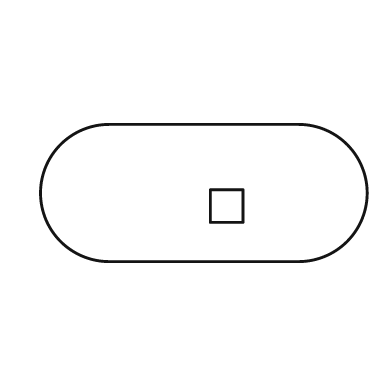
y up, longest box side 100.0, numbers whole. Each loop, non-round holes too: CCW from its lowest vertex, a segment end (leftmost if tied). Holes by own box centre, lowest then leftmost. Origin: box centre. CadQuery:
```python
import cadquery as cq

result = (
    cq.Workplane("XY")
    .moveTo(-29.0, -21.0)
    .lineTo(29.0, -21.0)
    .threePointArc((50.0, 0.0), (29.0, 21.0))
    .lineTo(-29.0, 21.0)
    .threePointArc((-50.0, 0.0), (-29.0, -21.0))
    .close()
    .moveTo(2.0, -9.0)
    .lineTo(12.0, -9.0)
    .lineTo(12.0, 1.0)
    .lineTo(2.0, 1.0)
    .close()
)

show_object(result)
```